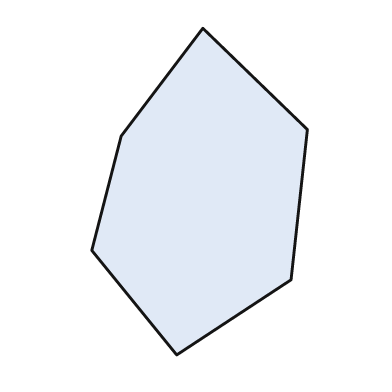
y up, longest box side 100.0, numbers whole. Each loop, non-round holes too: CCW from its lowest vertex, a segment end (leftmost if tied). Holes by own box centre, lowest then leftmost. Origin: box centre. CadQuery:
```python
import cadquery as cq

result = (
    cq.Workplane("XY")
    .moveTo(-7.0, -50.0)
    .lineTo(28.0, -27.0)
    .lineTo(33.0, 19.0)
    .lineTo(1.0, 50.0)
    .lineTo(-24.0, 17.0)
    .lineTo(-33.0, -18.0)
    .close()
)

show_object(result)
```